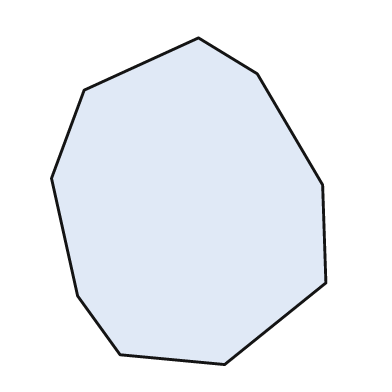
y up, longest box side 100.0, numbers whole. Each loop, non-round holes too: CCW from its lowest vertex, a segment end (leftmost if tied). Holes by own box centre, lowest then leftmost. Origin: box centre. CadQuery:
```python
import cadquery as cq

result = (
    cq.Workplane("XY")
    .moveTo(11.0, -50.0)
    .lineTo(42.0, -25.0)
    .lineTo(41.0, 5.0)
    .lineTo(21.0, 39.0)
    .lineTo(3.0, 50.0)
    .lineTo(-32.0, 34.0)
    .lineTo(-42.0, 7.0)
    .lineTo(-34.0, -29.0)
    .lineTo(-21.0, -47.0)
    .close()
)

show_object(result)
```